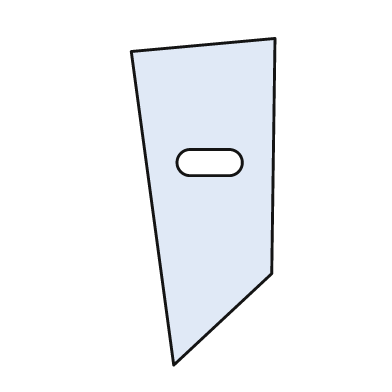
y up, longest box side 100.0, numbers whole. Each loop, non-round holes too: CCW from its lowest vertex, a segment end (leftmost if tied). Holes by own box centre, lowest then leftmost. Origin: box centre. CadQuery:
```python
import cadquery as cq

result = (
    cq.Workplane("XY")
    .moveTo(-9.0, -50.0)
    .lineTo(21.0, -22.0)
    .lineTo(22.0, 50.0)
    .lineTo(-22.0, 46.0)
    .close()
    .moveTo(-4.0, 8.0)
    .lineTo(8.0, 8.0)
    .threePointArc((12.0, 12.0), (8.0, 16.0))
    .lineTo(-4.0, 16.0)
    .threePointArc((-8.0, 12.0), (-4.0, 8.0))
    .close()
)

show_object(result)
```